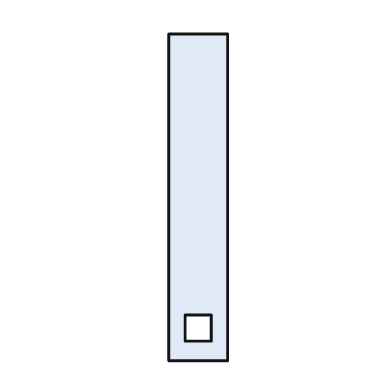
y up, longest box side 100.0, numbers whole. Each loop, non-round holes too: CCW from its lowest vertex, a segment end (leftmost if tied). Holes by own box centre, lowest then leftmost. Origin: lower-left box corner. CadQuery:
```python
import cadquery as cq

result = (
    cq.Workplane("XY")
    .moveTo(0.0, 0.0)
    .lineTo(18.0, 0.0)
    .lineTo(18.0, 100.0)
    .lineTo(0.0, 100.0)
    .close()
    .moveTo(5.0, 6.0)
    .lineTo(13.0, 6.0)
    .lineTo(13.0, 14.0)
    .lineTo(5.0, 14.0)
    .close()
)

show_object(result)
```